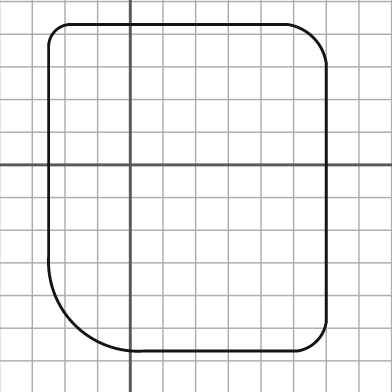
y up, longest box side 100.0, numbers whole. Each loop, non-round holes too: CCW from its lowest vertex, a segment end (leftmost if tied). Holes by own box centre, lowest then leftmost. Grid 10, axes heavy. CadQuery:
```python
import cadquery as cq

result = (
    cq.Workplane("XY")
    .moveTo(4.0, -57.0)
    .lineTo(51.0, -57.0)
    .threePointArc((57.0, -54.0), (60.0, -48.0))
    .lineTo(60.0, 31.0)
    .threePointArc((56.0, 39.0), (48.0, 43.0))
    .lineTo(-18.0, 43.0)
    .threePointArc((-23.0, 41.0), (-25.0, 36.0))
    .lineTo(-25.0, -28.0)
    .threePointArc((-17.0, -49.0), (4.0, -57.0))
    .close()
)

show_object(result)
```